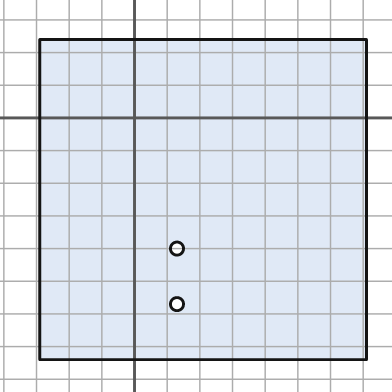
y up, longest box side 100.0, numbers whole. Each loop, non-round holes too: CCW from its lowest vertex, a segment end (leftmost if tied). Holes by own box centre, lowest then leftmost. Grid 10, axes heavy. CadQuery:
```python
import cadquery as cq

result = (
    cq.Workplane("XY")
    .moveTo(-29.0, -74.0)
    .lineTo(71.0, -74.0)
    .lineTo(71.0, 24.0)
    .lineTo(-29.0, 24.0)
    .close()
    .moveTo(13.0, -57.0)
    .circle(2.0)
    .moveTo(13.0, -40.0)
    .circle(2.0)
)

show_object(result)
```